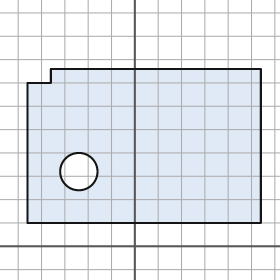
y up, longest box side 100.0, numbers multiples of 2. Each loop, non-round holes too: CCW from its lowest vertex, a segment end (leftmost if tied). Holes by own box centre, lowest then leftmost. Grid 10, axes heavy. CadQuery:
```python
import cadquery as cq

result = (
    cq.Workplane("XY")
    .moveTo(-46.0, 10.0)
    .lineTo(54.0, 10.0)
    .lineTo(54.0, 76.0)
    .lineTo(-36.0, 76.0)
    .lineTo(-36.0, 70.0)
    .lineTo(-46.0, 70.0)
    .close()
    .moveTo(-24.0, 32.0)
    .circle(8.0)
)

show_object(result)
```